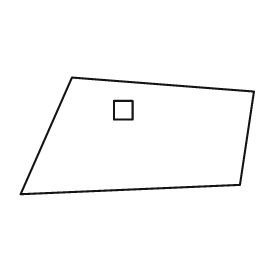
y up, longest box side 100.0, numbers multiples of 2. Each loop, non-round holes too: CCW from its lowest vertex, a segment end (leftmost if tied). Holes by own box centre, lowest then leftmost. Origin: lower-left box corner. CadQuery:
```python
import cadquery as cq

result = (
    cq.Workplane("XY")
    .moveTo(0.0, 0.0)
    .lineTo(94.0, 4.0)
    .lineTo(100.0, 44.0)
    .lineTo(22.0, 50.0)
    .close()
    .moveTo(40.0, 32.0)
    .lineTo(48.0, 32.0)
    .lineTo(48.0, 40.0)
    .lineTo(40.0, 40.0)
    .close()
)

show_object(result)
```